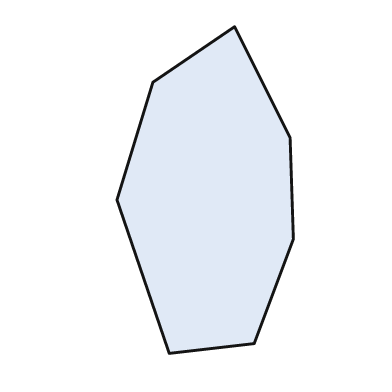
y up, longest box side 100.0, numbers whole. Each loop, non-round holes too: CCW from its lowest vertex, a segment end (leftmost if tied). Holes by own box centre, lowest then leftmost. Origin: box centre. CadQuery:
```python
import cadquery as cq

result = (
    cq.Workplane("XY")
    .moveTo(-11.0, -50.0)
    .lineTo(15.0, -47.0)
    .lineTo(27.0, -15.0)
    .lineTo(26.0, 16.0)
    .lineTo(9.0, 50.0)
    .lineTo(-16.0, 33.0)
    .lineTo(-27.0, -3.0)
    .close()
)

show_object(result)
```